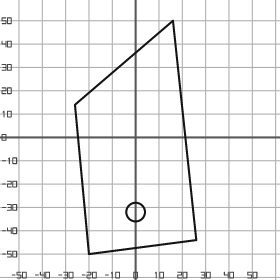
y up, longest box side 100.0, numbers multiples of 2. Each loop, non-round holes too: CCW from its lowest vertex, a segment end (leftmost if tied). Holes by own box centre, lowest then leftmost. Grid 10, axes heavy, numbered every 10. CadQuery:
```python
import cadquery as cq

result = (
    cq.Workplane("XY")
    .moveTo(-20.0, -50.0)
    .lineTo(26.0, -44.0)
    .lineTo(16.0, 50.0)
    .lineTo(-26.0, 14.0)
    .close()
    .moveTo(0.0, -32.0)
    .circle(4.0)
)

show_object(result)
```